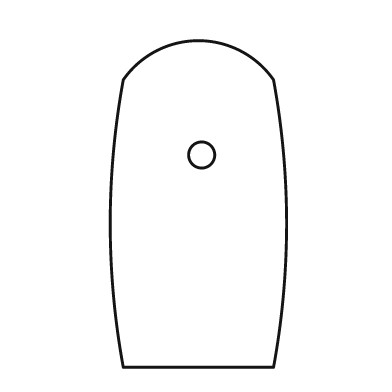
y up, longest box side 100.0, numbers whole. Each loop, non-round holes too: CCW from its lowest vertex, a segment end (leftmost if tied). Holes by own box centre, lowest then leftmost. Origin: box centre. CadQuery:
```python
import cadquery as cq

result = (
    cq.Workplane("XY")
    .moveTo(-23.0, -50.0)
    .lineTo(23.0, -50.0)
    .threePointArc((27.0, -6.0), (23.0, 38.0))
    .threePointArc((0.0, 50.0), (-23.0, 38.0))
    .threePointArc((-27.0, -6.0), (-23.0, -50.0))
    .close()
    .moveTo(1.0, 15.0)
    .circle(4.0)
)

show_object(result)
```